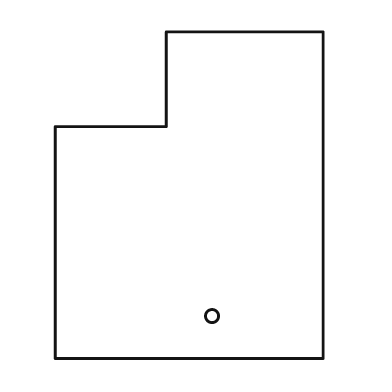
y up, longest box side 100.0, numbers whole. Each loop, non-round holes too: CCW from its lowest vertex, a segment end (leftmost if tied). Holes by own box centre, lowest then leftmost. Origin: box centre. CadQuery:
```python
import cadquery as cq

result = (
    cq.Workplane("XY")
    .moveTo(-41.0, -50.0)
    .lineTo(41.0, -50.0)
    .lineTo(41.0, 50.0)
    .lineTo(-7.0, 50.0)
    .lineTo(-7.0, 21.0)
    .lineTo(-41.0, 21.0)
    .close()
    .moveTo(7.0, -37.0)
    .circle(2.0)
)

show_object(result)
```